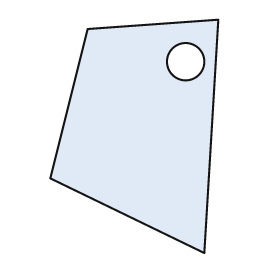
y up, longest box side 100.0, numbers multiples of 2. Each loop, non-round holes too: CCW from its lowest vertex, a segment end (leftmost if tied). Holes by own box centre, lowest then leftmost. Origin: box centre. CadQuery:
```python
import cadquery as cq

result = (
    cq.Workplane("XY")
    .moveTo(30.0, -50.0)
    .lineTo(36.0, 50.0)
    .lineTo(-20.0, 46.0)
    .lineTo(-36.0, -18.0)
    .close()
    .moveTo(22.0, 32.0)
    .circle(8.0)
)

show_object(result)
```